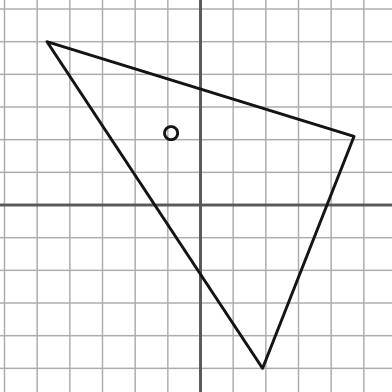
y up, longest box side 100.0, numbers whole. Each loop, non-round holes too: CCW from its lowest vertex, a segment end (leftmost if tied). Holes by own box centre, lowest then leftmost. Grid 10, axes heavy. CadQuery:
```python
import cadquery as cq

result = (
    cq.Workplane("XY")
    .moveTo(19.0, -50.0)
    .lineTo(47.0, 21.0)
    .lineTo(-47.0, 50.0)
    .close()
    .moveTo(-9.0, 22.0)
    .circle(2.0)
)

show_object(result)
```